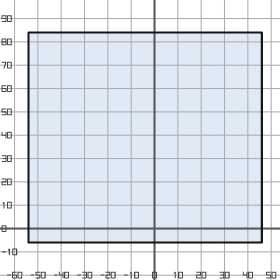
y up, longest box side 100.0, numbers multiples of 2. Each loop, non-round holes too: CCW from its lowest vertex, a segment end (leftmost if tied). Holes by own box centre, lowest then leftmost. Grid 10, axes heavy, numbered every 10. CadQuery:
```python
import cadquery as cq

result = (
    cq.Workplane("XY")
    .moveTo(-54.0, -6.0)
    .lineTo(46.0, -6.0)
    .lineTo(46.0, 84.0)
    .lineTo(-54.0, 84.0)
    .close()
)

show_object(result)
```